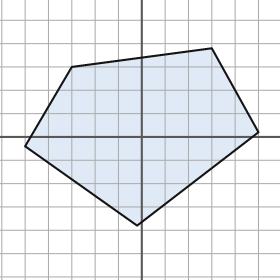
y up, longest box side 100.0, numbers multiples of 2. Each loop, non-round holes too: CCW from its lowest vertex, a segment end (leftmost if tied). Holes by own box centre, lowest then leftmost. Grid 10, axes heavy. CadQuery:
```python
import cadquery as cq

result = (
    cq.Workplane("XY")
    .moveTo(-2.0, -38.0)
    .lineTo(50.0, 2.0)
    .lineTo(30.0, 38.0)
    .lineTo(-30.0, 30.0)
    .lineTo(-50.0, -4.0)
    .close()
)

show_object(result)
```